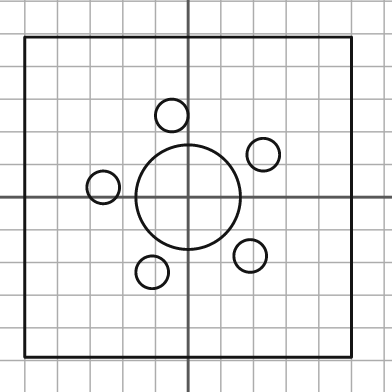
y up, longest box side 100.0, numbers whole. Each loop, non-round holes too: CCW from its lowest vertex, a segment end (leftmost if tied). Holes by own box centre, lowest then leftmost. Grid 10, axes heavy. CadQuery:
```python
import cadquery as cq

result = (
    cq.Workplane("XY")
    .moveTo(-50.0, -49.0)
    .lineTo(50.0, -49.0)
    .lineTo(50.0, 49.0)
    .lineTo(-50.0, 49.0)
    .close()
    .moveTo(-11.0, -23.0)
    .circle(5.0)
    .moveTo(19.0, -18.0)
    .circle(5.0)
    .moveTo(0.0, 0.0)
    .circle(16.0)
    .moveTo(-26.0, 3.0)
    .circle(5.0)
    .moveTo(23.0, 13.0)
    .circle(5.0)
    .moveTo(-5.0, 25.0)
    .circle(5.0)
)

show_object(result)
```